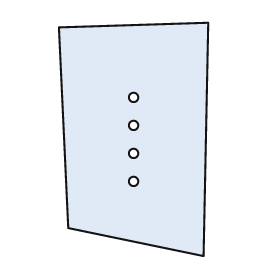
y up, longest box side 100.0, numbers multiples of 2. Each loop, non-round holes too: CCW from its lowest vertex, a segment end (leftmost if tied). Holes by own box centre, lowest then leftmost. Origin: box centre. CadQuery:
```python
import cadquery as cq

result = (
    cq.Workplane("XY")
    .moveTo(30.0, -50.0)
    .lineTo(32.0, 50.0)
    .lineTo(-32.0, 48.0)
    .lineTo(-28.0, -38.0)
    .close()
    .moveTo(0.0, -18.0)
    .circle(2.0)
    .moveTo(0.0, -6.0)
    .circle(2.0)
    .moveTo(0.0, 6.0)
    .circle(2.0)
    .moveTo(0.0, 18.0)
    .circle(2.0)
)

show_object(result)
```